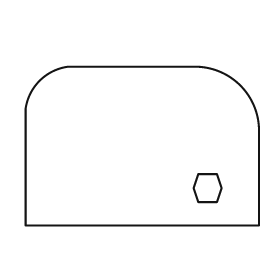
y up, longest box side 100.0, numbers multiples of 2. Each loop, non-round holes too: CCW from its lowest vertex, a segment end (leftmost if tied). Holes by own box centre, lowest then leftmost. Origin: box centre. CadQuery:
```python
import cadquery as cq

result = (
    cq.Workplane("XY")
    .moveTo(-50.0, -34.0)
    .lineTo(50.0, -34.0)
    .lineTo(50.0, 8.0)
    .threePointArc((42.0, 26.0), (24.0, 34.0))
    .lineTo(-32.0, 34.0)
    .threePointArc((-44.0, 28.0), (-50.0, 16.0))
    .close()
    .moveTo(24.0, -24.0)
    .lineTo(32.0, -24.0)
    .lineTo(34.0, -18.0)
    .lineTo(32.0, -12.0)
    .lineTo(24.0, -12.0)
    .lineTo(22.0, -18.0)
    .close()
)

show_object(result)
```